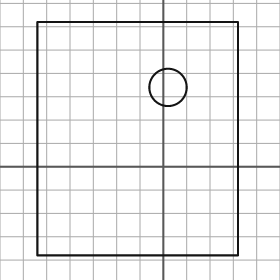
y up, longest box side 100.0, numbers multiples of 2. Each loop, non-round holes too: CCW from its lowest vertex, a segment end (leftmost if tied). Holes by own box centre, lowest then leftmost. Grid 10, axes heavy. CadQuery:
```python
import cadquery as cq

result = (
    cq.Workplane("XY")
    .moveTo(-54.0, -38.0)
    .lineTo(32.0, -38.0)
    .lineTo(32.0, 62.0)
    .lineTo(-54.0, 62.0)
    .close()
    .moveTo(2.0, 34.0)
    .circle(8.0)
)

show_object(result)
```